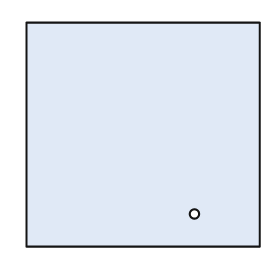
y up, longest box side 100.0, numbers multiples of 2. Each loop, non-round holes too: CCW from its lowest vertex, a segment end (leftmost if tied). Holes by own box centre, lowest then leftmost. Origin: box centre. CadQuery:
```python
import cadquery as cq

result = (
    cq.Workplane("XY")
    .moveTo(-50.0, -48.0)
    .lineTo(50.0, -48.0)
    .lineTo(50.0, 48.0)
    .lineTo(-50.0, 48.0)
    .close()
    .moveTo(22.0, -34.0)
    .circle(2.0)
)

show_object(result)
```